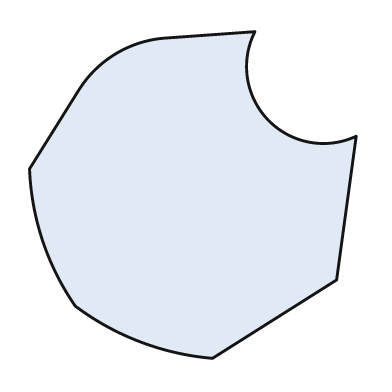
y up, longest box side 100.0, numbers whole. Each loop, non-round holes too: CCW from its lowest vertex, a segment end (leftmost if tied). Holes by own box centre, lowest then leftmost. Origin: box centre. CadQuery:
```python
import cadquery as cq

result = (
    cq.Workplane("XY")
    .moveTo(6.0, -50.0)
    .lineTo(44.0, -26.0)
    .lineTo(50.0, 18.0)
    .threePointArc((23.0, 23.0), (19.0, 50.0))
    .lineTo(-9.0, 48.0)
    .threePointArc((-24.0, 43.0), (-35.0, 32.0))
    .lineTo(-50.0, 8.0)
    .threePointArc((-46.0, -14.0), (-36.0, -34.0))
    .threePointArc((-16.0, -45.0), (6.0, -50.0))
    .close()
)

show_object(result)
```